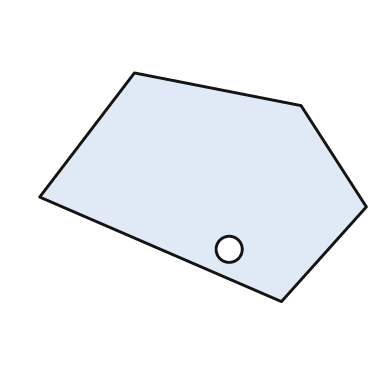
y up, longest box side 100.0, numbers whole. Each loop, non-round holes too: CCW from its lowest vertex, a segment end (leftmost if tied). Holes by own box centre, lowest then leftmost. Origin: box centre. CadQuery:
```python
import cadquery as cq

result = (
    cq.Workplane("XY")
    .moveTo(24.0, -35.0)
    .lineTo(50.0, -6.0)
    .lineTo(30.0, 25.0)
    .lineTo(-21.0, 35.0)
    .lineTo(-50.0, -3.0)
    .close()
    .moveTo(8.0, -19.0)
    .circle(4.0)
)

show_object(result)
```